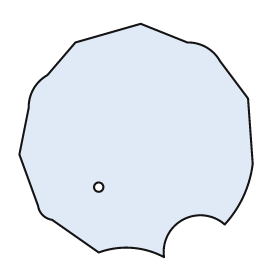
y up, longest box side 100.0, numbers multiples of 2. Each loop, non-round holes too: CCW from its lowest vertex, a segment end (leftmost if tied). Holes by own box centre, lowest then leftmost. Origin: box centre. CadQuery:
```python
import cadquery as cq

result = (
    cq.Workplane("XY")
    .moveTo(12.0, -50.0)
    .threePointArc((20.0, -34.0), (38.0, -36.0))
    .threePointArc((46.0, -24.0), (50.0, -10.0))
    .lineTo(48.0, 18.0)
    .lineTo(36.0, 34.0)
    .threePointArc((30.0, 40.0), (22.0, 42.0))
    .lineTo(2.0, 50.0)
    .lineTo(-26.0, 42.0)
    .lineTo(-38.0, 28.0)
    .threePointArc((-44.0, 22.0), (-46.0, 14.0))
    .lineTo(-50.0, -6.0)
    .lineTo(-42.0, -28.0)
    .threePointArc((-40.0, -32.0), (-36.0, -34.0))
    .lineTo(-16.0, -48.0)
    .threePointArc((-2.0, -46.0), (12.0, -50.0))
    .close()
    .moveTo(-16.0, -20.0)
    .circle(2.0)
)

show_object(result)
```